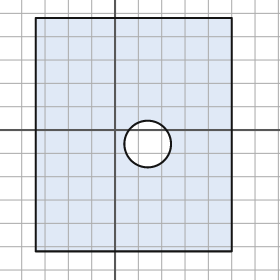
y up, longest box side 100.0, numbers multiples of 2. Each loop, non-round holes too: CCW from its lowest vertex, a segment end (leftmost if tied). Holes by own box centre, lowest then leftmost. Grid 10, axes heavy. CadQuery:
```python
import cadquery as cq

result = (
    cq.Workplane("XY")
    .moveTo(-34.0, -52.0)
    .lineTo(50.0, -52.0)
    .lineTo(50.0, 48.0)
    .lineTo(-34.0, 48.0)
    .close()
    .moveTo(14.0, -6.0)
    .circle(10.0)
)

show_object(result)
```